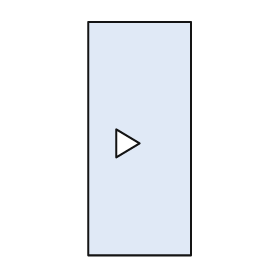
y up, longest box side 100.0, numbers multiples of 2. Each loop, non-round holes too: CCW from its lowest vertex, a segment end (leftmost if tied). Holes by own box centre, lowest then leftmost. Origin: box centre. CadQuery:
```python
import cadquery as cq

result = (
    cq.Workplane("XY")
    .moveTo(-22.0, -50.0)
    .lineTo(22.0, -50.0)
    .lineTo(22.0, 50.0)
    .lineTo(-22.0, 50.0)
    .close()
    .moveTo(-10.0, -8.0)
    .lineTo(0.0, -2.0)
    .lineTo(-10.0, 4.0)
    .close()
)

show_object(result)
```